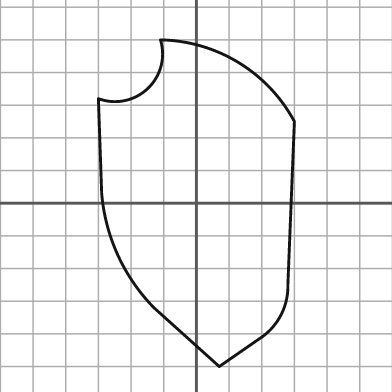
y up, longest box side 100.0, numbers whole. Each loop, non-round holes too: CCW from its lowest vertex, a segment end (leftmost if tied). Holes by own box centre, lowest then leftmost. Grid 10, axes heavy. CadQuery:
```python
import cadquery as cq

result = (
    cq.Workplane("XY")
    .moveTo(7.0, -50.0)
    .lineTo(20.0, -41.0)
    .threePointArc((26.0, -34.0), (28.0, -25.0))
    .lineTo(30.0, 25.0)
    .threePointArc((13.0, 43.0), (-11.0, 50.0))
    .threePointArc((-15.0, 35.0), (-30.0, 32.0))
    .lineTo(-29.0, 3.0)
    .threePointArc((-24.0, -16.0), (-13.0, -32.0))
    .close()
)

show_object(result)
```